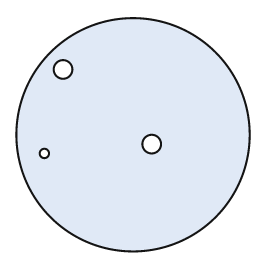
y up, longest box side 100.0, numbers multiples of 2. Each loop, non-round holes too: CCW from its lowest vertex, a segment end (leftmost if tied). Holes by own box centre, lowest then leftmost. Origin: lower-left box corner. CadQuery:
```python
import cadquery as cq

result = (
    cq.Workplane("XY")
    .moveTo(50.0, 50.0)
    .circle(50.0)
    .moveTo(12.0, 42.0)
    .circle(2.0)
    .moveTo(58.0, 46.0)
    .circle(4.0)
    .moveTo(20.0, 78.0)
    .circle(4.0)
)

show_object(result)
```